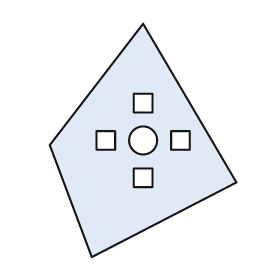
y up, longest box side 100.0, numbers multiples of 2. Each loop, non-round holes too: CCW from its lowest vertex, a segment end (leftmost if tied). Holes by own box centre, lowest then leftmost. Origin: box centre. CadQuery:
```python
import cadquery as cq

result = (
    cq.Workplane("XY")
    .moveTo(-22.0, -50.0)
    .lineTo(40.0, -18.0)
    .lineTo(0.0, 50.0)
    .lineTo(-40.0, -2.0)
    .close()
    .moveTo(-4.0, -20.0)
    .lineTo(4.0, -20.0)
    .lineTo(4.0, -12.0)
    .lineTo(-4.0, -12.0)
    .close()
    .moveTo(-20.0, -4.0)
    .lineTo(-12.0, -4.0)
    .lineTo(-12.0, 4.0)
    .lineTo(-20.0, 4.0)
    .close()
    .moveTo(0.0, 0.0)
    .circle(6.0)
    .moveTo(12.0, -4.0)
    .lineTo(20.0, -4.0)
    .lineTo(20.0, 4.0)
    .lineTo(12.0, 4.0)
    .close()
    .moveTo(-4.0, 12.0)
    .lineTo(4.0, 12.0)
    .lineTo(4.0, 20.0)
    .lineTo(-4.0, 20.0)
    .close()
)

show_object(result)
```